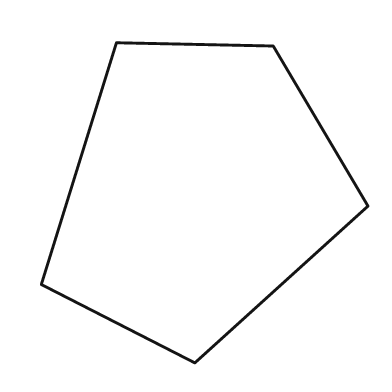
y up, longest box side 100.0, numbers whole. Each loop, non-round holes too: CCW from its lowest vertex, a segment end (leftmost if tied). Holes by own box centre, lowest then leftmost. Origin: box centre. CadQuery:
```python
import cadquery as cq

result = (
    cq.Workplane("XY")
    .moveTo(-3.0, -49.0)
    .lineTo(50.0, -1.0)
    .lineTo(21.0, 48.0)
    .lineTo(-27.0, 49.0)
    .lineTo(-50.0, -25.0)
    .close()
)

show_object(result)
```